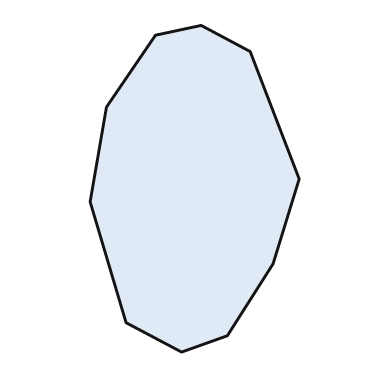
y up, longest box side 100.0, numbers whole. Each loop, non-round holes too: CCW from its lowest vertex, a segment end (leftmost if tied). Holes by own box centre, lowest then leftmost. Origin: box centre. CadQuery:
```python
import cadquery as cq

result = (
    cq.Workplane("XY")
    .moveTo(-4.0, -50.0)
    .lineTo(10.0, -45.0)
    .lineTo(24.0, -23.0)
    .lineTo(32.0, 3.0)
    .lineTo(17.0, 42.0)
    .lineTo(2.0, 50.0)
    .lineTo(-12.0, 47.0)
    .lineTo(-27.0, 25.0)
    .lineTo(-32.0, -4.0)
    .lineTo(-21.0, -41.0)
    .close()
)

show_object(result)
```